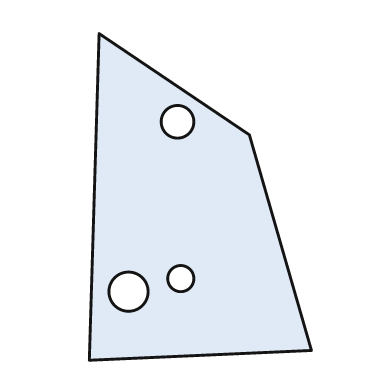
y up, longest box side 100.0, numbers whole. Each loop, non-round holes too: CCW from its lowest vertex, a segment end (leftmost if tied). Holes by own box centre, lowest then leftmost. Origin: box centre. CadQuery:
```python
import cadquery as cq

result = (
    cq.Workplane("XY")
    .moveTo(-34.0, -50.0)
    .lineTo(34.0, -47.0)
    .lineTo(15.0, 19.0)
    .lineTo(-31.0, 50.0)
    .close()
    .moveTo(-22.0, -29.0)
    .circle(6.0)
    .moveTo(-6.0, -25.0)
    .circle(4.0)
    .moveTo(-7.0, 23.0)
    .circle(5.0)
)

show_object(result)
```